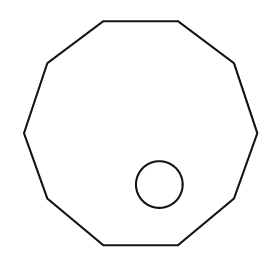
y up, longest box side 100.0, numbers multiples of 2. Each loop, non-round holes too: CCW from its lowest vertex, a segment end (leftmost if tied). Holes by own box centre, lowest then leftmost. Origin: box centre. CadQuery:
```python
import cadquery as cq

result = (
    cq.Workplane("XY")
    .moveTo(-16.0, -48.0)
    .lineTo(16.0, -48.0)
    .lineTo(40.0, -28.0)
    .lineTo(50.0, 0.0)
    .lineTo(40.0, 30.0)
    .lineTo(16.0, 48.0)
    .lineTo(-16.0, 48.0)
    .lineTo(-40.0, 30.0)
    .lineTo(-50.0, 0.0)
    .lineTo(-40.0, -28.0)
    .close()
    .moveTo(8.0, -22.0)
    .circle(10.0)
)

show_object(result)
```